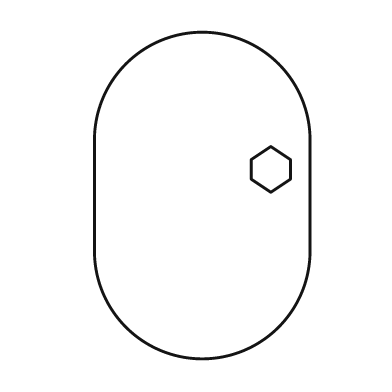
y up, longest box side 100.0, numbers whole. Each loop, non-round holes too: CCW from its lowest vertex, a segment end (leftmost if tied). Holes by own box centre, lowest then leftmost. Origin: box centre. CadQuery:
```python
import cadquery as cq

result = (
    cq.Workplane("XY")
    .moveTo(-33.0, -17.0)
    .threePointArc((0.0, -50.0), (33.0, -17.0))
    .lineTo(33.0, 17.0)
    .threePointArc((0.0, 50.0), (-33.0, 17.0))
    .close()
    .moveTo(21.0, 1.0)
    .lineTo(27.0, 5.0)
    .lineTo(27.0, 11.0)
    .lineTo(21.0, 15.0)
    .lineTo(15.0, 11.0)
    .lineTo(15.0, 5.0)
    .close()
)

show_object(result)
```